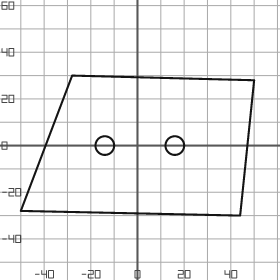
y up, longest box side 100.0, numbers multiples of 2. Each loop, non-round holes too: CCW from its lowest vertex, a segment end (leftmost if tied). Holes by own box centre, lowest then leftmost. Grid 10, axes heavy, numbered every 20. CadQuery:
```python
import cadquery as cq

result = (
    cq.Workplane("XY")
    .moveTo(44.0, -30.0)
    .lineTo(50.0, 28.0)
    .lineTo(-28.0, 30.0)
    .lineTo(-50.0, -28.0)
    .close()
    .moveTo(-14.0, 0.0)
    .circle(4.0)
    .moveTo(16.0, 0.0)
    .circle(4.0)
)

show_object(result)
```